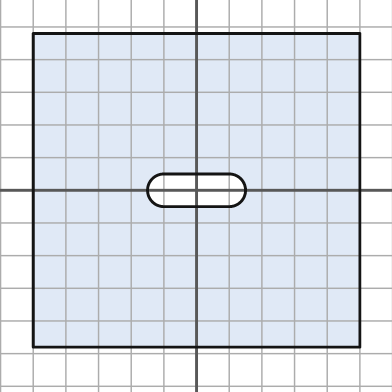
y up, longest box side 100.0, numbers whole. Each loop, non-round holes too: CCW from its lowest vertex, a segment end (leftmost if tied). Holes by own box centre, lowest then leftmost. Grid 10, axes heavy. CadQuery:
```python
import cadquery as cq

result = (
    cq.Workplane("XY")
    .moveTo(-50.0, -48.0)
    .lineTo(50.0, -48.0)
    .lineTo(50.0, 48.0)
    .lineTo(-50.0, 48.0)
    .close()
    .moveTo(-10.0, -5.0)
    .lineTo(10.0, -5.0)
    .threePointArc((15.0, 0.0), (10.0, 5.0))
    .lineTo(-10.0, 5.0)
    .threePointArc((-15.0, 0.0), (-10.0, -5.0))
    .close()
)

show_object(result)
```